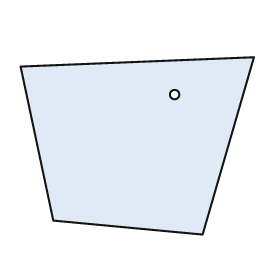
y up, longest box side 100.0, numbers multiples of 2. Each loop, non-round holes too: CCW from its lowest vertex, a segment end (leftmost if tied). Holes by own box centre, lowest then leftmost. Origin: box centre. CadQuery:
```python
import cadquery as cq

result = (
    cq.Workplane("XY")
    .moveTo(28.0, -38.0)
    .lineTo(50.0, 38.0)
    .lineTo(-50.0, 34.0)
    .lineTo(-36.0, -32.0)
    .close()
    .moveTo(16.0, 22.0)
    .circle(2.0)
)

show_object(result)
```